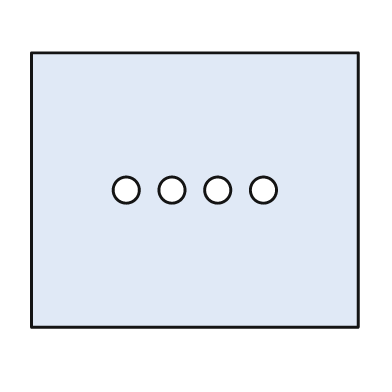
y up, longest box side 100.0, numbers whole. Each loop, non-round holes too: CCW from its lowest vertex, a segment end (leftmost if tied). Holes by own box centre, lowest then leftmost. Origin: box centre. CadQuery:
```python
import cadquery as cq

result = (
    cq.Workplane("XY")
    .moveTo(-50.0, -42.0)
    .lineTo(50.0, -42.0)
    .lineTo(50.0, 42.0)
    .lineTo(-50.0, 42.0)
    .close()
    .moveTo(-21.0, 0.0)
    .circle(4.0)
    .moveTo(-7.0, 0.0)
    .circle(4.0)
    .moveTo(7.0, 0.0)
    .circle(4.0)
    .moveTo(21.0, 0.0)
    .circle(4.0)
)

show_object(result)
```